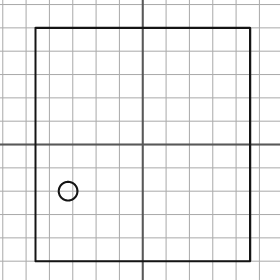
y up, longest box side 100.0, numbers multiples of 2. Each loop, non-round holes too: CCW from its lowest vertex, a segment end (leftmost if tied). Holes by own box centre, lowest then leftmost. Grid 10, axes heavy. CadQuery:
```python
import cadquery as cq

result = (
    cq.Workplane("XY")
    .moveTo(-46.0, -50.0)
    .lineTo(46.0, -50.0)
    .lineTo(46.0, 50.0)
    .lineTo(-46.0, 50.0)
    .close()
    .moveTo(-32.0, -20.0)
    .circle(4.0)
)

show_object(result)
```